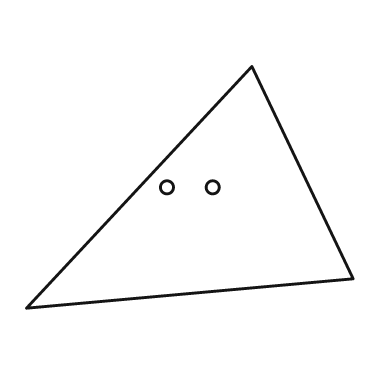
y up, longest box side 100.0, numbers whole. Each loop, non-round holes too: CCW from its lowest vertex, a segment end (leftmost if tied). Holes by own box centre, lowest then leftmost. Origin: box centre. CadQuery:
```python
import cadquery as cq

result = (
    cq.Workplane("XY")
    .moveTo(-50.0, -37.0)
    .lineTo(50.0, -28.0)
    .lineTo(19.0, 37.0)
    .close()
    .moveTo(-7.0, 0.0)
    .circle(2.0)
    .moveTo(7.0, 0.0)
    .circle(2.0)
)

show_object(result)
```